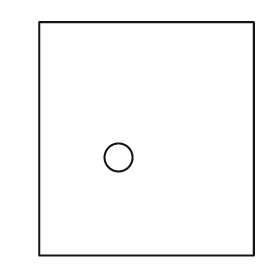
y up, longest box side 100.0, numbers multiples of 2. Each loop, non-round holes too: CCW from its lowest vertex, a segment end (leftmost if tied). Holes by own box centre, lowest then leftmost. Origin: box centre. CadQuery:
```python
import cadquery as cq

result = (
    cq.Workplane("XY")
    .moveTo(-46.0, -50.0)
    .lineTo(46.0, -50.0)
    .lineTo(46.0, 50.0)
    .lineTo(-46.0, 50.0)
    .close()
    .moveTo(-12.0, -8.0)
    .circle(6.0)
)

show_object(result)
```